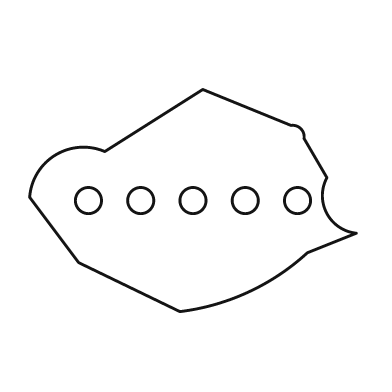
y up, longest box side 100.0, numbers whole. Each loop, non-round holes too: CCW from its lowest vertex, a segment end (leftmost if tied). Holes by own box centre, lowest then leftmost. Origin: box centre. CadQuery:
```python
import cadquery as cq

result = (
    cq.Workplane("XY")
    .moveTo(-4.0, -34.0)
    .threePointArc((17.0, -28.0), (35.0, -16.0))
    .lineTo(50.0, -10.0)
    .threePointArc((41.0, -4.0), (41.0, 7.0))
    .lineTo(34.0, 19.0)
    .threePointArc((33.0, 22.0), (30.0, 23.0))
    .lineTo(3.0, 34.0)
    .lineTo(-27.0, 15.0)
    .threePointArc((-42.0, 14.0), (-50.0, 1.0))
    .lineTo(-35.0, -19.0)
    .close()
    .moveTo(-32.0, 0.0)
    .circle(4.0)
    .moveTo(-16.0, 0.0)
    .circle(4.0)
    .moveTo(0.0, 0.0)
    .circle(4.0)
    .moveTo(16.0, 0.0)
    .circle(4.0)
    .moveTo(32.0, 0.0)
    .circle(4.0)
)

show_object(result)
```